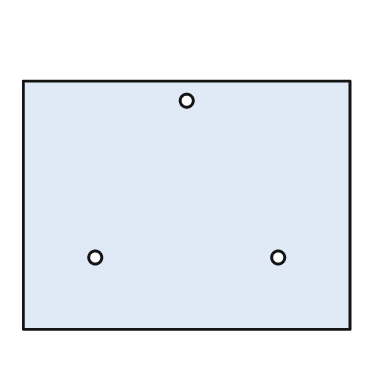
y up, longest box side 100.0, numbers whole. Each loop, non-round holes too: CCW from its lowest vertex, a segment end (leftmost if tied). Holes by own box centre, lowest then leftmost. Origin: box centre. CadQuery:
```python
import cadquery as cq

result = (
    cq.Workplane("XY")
    .moveTo(-50.0, -38.0)
    .lineTo(50.0, -38.0)
    .lineTo(50.0, 38.0)
    .lineTo(-50.0, 38.0)
    .close()
    .moveTo(-28.0, -16.0)
    .circle(2.0)
    .moveTo(28.0, -16.0)
    .circle(2.0)
    .moveTo(0.0, 32.0)
    .circle(2.0)
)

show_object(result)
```